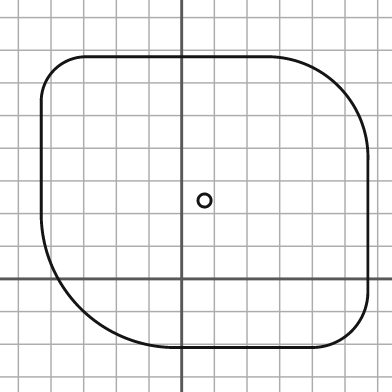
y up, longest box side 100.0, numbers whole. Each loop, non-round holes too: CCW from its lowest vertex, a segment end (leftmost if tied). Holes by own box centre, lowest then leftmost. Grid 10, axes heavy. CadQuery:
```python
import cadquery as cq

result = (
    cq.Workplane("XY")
    .moveTo(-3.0, -21.0)
    .lineTo(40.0, -21.0)
    .threePointArc((52.0, -16.0), (57.0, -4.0))
    .lineTo(57.0, 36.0)
    .threePointArc((48.0, 59.0), (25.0, 68.0))
    .lineTo(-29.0, 68.0)
    .threePointArc((-39.0, 64.0), (-43.0, 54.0))
    .lineTo(-43.0, 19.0)
    .threePointArc((-31.0, -9.0), (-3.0, -21.0))
    .close()
    .moveTo(7.0, 24.0)
    .circle(2.0)
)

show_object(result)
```